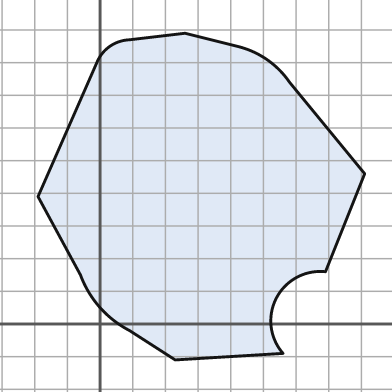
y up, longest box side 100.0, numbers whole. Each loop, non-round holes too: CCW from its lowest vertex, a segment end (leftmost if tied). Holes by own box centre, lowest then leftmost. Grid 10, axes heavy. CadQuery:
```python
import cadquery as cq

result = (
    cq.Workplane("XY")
    .moveTo(23.0, -11.0)
    .lineTo(56.0, -9.0)
    .threePointArc((54.0, 8.0), (69.0, 16.0))
    .lineTo(81.0, 46.0)
    .lineTo(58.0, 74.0)
    .threePointArc((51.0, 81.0), (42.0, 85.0))
    .lineTo(26.0, 89.0)
    .lineTo(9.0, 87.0)
    .threePointArc((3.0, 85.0), (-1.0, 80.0))
    .lineTo(-19.0, 39.0)
    .lineTo(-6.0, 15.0)
    .threePointArc((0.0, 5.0), (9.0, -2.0))
    .close()
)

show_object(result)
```